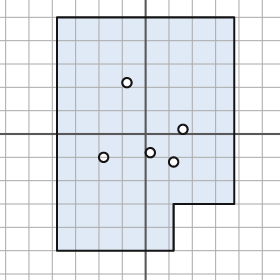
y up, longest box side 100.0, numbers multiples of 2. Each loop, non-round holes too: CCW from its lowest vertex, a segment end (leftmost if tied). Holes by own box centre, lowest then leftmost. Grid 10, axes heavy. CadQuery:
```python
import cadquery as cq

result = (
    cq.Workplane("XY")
    .moveTo(-38.0, -50.0)
    .lineTo(12.0, -50.0)
    .lineTo(12.0, -30.0)
    .lineTo(38.0, -30.0)
    .lineTo(38.0, 50.0)
    .lineTo(-38.0, 50.0)
    .close()
    .moveTo(12.0, -12.0)
    .circle(2.0)
    .moveTo(-18.0, -10.0)
    .circle(2.0)
    .moveTo(2.0, -8.0)
    .circle(2.0)
    .moveTo(16.0, 2.0)
    .circle(2.0)
    .moveTo(-8.0, 22.0)
    .circle(2.0)
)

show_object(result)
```